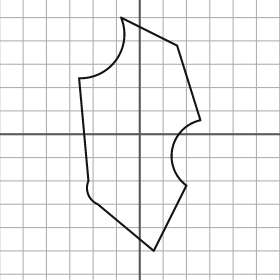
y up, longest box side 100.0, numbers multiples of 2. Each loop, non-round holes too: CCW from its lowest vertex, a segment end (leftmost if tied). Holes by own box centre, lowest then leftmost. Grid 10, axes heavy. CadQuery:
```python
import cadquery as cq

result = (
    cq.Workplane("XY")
    .moveTo(6.0, -50.0)
    .lineTo(20.0, -22.0)
    .threePointArc((14.0, -6.0), (26.0, 6.0))
    .lineTo(16.0, 38.0)
    .lineTo(-8.0, 50.0)
    .threePointArc((-10.0, 32.0), (-26.0, 24.0))
    .lineTo(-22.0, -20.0)
    .threePointArc((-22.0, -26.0), (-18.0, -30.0))
    .close()
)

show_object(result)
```